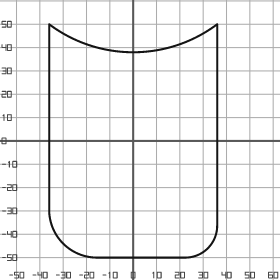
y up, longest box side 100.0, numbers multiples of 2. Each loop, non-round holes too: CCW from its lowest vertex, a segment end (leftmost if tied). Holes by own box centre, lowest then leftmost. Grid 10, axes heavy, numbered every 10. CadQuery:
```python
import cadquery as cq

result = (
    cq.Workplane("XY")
    .moveTo(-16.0, -50.0)
    .lineTo(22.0, -50.0)
    .threePointArc((32.0, -46.0), (36.0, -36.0))
    .lineTo(36.0, 50.0)
    .threePointArc((0.0, 38.0), (-36.0, 50.0))
    .lineTo(-36.0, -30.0)
    .threePointArc((-30.0, -44.0), (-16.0, -50.0))
    .close()
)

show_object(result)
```